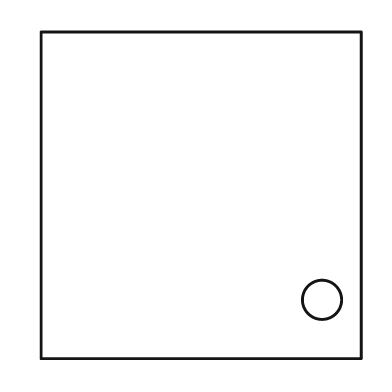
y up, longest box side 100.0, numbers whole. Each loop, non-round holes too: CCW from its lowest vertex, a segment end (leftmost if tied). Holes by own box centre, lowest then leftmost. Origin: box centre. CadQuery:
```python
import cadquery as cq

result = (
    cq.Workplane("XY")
    .moveTo(-49.0, -50.0)
    .lineTo(49.0, -50.0)
    .lineTo(49.0, 50.0)
    .lineTo(-49.0, 50.0)
    .close()
    .moveTo(37.0, -32.0)
    .circle(6.0)
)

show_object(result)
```